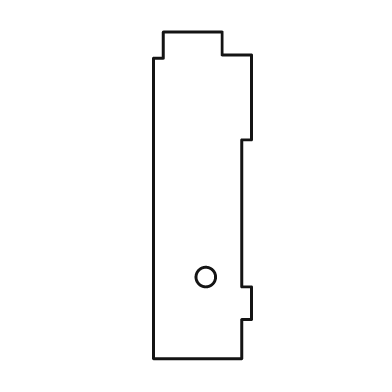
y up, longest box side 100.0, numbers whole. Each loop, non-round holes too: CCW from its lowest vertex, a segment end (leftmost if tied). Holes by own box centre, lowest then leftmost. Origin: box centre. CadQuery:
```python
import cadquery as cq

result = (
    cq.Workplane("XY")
    .moveTo(-15.0, -50.0)
    .lineTo(12.0, -50.0)
    .lineTo(12.0, -38.0)
    .lineTo(15.0, -38.0)
    .lineTo(15.0, -28.0)
    .lineTo(12.0, -28.0)
    .lineTo(12.0, 17.0)
    .lineTo(15.0, 17.0)
    .lineTo(15.0, 43.0)
    .lineTo(6.0, 43.0)
    .lineTo(6.0, 50.0)
    .lineTo(-12.0, 50.0)
    .lineTo(-12.0, 42.0)
    .lineTo(-15.0, 42.0)
    .close()
    .moveTo(1.0, -25.0)
    .circle(3.0)
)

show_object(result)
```